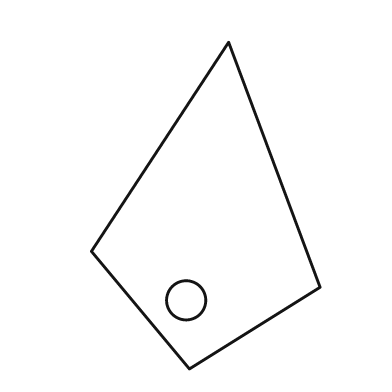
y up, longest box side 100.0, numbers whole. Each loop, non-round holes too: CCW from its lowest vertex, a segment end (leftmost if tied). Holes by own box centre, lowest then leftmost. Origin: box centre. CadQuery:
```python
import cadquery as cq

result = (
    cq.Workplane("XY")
    .moveTo(-5.0, -50.0)
    .lineTo(35.0, -25.0)
    .lineTo(7.0, 50.0)
    .lineTo(-35.0, -14.0)
    .close()
    .moveTo(-6.0, -29.0)
    .circle(6.0)
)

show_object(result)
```